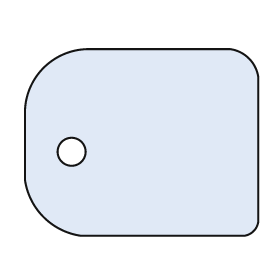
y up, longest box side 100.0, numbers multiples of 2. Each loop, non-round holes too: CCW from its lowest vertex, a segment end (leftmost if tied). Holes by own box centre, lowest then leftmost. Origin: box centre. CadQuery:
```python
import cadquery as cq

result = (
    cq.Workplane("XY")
    .moveTo(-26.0, -40.0)
    .lineTo(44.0, -40.0)
    .threePointArc((48.0, -38.0), (50.0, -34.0))
    .lineTo(50.0, 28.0)
    .threePointArc((46.0, 36.0), (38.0, 40.0))
    .lineTo(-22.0, 40.0)
    .threePointArc((-42.0, 32.0), (-50.0, 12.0))
    .lineTo(-50.0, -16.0)
    .threePointArc((-42.0, -32.0), (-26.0, -40.0))
    .close()
    .moveTo(-30.0, -4.0)
    .circle(6.0)
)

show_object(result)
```